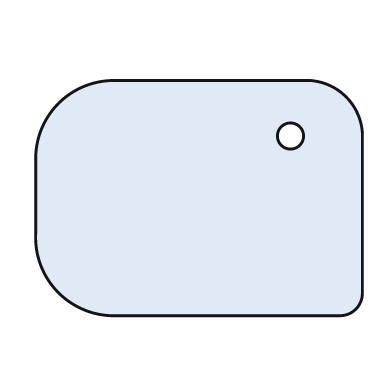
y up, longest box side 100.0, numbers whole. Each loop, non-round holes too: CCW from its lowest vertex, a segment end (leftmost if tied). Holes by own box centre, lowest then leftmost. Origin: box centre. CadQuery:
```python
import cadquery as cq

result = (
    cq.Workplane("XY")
    .moveTo(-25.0, -36.0)
    .lineTo(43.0, -36.0)
    .threePointArc((48.0, -34.0), (50.0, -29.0))
    .lineTo(50.0, 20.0)
    .threePointArc((45.0, 31.0), (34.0, 36.0))
    .lineTo(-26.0, 36.0)
    .threePointArc((-43.0, 29.0), (-50.0, 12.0))
    .lineTo(-50.0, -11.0)
    .threePointArc((-43.0, -29.0), (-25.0, -36.0))
    .close()
    .moveTo(28.0, 19.0)
    .circle(4.0)
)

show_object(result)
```